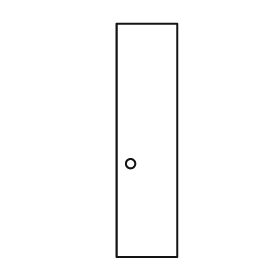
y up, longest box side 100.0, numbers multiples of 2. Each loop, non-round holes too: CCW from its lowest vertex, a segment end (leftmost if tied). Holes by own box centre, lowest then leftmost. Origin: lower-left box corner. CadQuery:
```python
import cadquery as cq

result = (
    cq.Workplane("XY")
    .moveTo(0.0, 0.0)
    .lineTo(26.0, 0.0)
    .lineTo(26.0, 100.0)
    .lineTo(0.0, 100.0)
    .close()
    .moveTo(6.0, 40.0)
    .circle(2.0)
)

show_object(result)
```